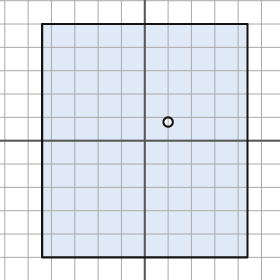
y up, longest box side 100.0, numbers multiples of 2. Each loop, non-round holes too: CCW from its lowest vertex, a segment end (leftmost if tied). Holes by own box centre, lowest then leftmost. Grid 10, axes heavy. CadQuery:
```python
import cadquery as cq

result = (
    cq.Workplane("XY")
    .moveTo(-44.0, -50.0)
    .lineTo(44.0, -50.0)
    .lineTo(44.0, 50.0)
    .lineTo(-44.0, 50.0)
    .close()
    .moveTo(10.0, 8.0)
    .circle(2.0)
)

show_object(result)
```